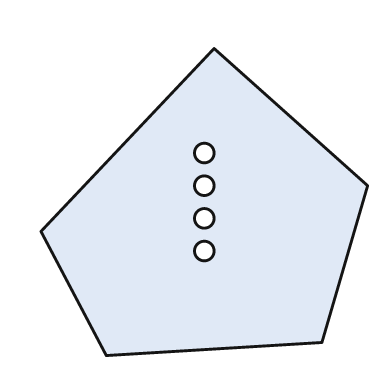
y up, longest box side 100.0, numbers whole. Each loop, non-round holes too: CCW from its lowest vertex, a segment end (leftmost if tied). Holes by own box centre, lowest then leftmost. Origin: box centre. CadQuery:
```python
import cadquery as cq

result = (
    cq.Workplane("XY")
    .moveTo(-30.0, -47.0)
    .lineTo(36.0, -43.0)
    .lineTo(50.0, 5.0)
    .lineTo(3.0, 47.0)
    .lineTo(-50.0, -9.0)
    .close()
    .moveTo(0.0, -15.0)
    .circle(3.0)
    .moveTo(0.0, -5.0)
    .circle(3.0)
    .moveTo(0.0, 5.0)
    .circle(3.0)
    .moveTo(0.0, 15.0)
    .circle(3.0)
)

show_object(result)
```